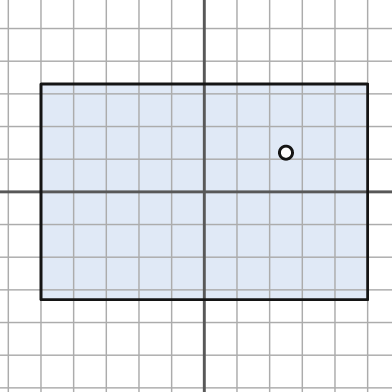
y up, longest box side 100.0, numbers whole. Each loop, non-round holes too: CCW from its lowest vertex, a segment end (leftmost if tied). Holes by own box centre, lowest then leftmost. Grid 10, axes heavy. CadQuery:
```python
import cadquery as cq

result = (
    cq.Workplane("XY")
    .moveTo(-50.0, -33.0)
    .lineTo(50.0, -33.0)
    .lineTo(50.0, 33.0)
    .lineTo(-50.0, 33.0)
    .close()
    .moveTo(25.0, 12.0)
    .circle(2.0)
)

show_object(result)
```